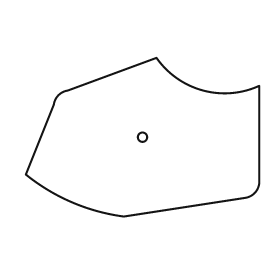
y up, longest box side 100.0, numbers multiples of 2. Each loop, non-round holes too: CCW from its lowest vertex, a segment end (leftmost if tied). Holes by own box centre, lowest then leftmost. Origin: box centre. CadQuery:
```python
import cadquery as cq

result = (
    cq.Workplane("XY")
    .moveTo(-8.0, -34.0)
    .lineTo(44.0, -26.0)
    .threePointArc((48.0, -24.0), (50.0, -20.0))
    .lineTo(50.0, 22.0)
    .threePointArc((26.0, 20.0), (6.0, 34.0))
    .lineTo(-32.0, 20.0)
    .threePointArc((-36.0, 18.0), (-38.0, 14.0))
    .lineTo(-50.0, -16.0)
    .threePointArc((-30.0, -28.0), (-8.0, -34.0))
    .close()
    .moveTo(0.0, 0.0)
    .circle(2.0)
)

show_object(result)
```